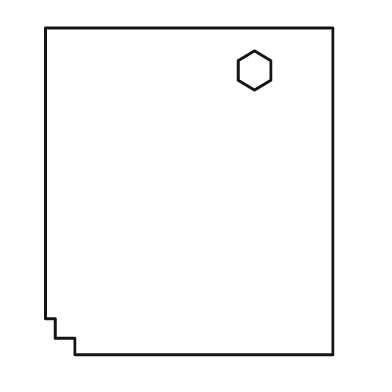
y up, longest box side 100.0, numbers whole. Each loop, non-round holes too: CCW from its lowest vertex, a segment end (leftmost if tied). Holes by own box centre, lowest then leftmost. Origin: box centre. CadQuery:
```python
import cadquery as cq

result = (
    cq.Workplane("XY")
    .moveTo(-35.0, -50.0)
    .lineTo(44.0, -50.0)
    .lineTo(44.0, 50.0)
    .lineTo(-44.0, 50.0)
    .lineTo(-44.0, -39.0)
    .lineTo(-41.0, -39.0)
    .lineTo(-41.0, -45.0)
    .lineTo(-35.0, -45.0)
    .close()
    .moveTo(20.0, 31.0)
    .lineTo(25.0, 34.0)
    .lineTo(25.0, 40.0)
    .lineTo(20.0, 43.0)
    .lineTo(15.0, 40.0)
    .lineTo(15.0, 34.0)
    .close()
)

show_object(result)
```